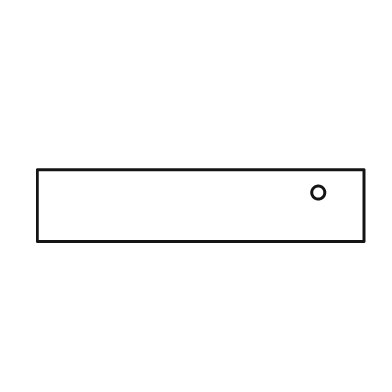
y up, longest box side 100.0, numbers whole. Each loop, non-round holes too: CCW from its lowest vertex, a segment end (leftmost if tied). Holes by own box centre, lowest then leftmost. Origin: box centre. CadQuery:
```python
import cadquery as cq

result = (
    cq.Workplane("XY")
    .moveTo(-50.0, -11.0)
    .lineTo(50.0, -11.0)
    .lineTo(50.0, 11.0)
    .lineTo(-50.0, 11.0)
    .close()
    .moveTo(36.0, 4.0)
    .circle(2.0)
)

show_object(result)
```